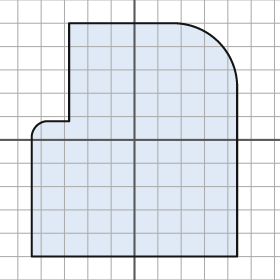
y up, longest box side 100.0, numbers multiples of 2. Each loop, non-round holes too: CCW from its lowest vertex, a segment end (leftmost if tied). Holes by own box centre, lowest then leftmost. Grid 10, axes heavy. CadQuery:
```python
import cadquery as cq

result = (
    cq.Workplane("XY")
    .moveTo(-44.0, -50.0)
    .lineTo(44.0, -50.0)
    .lineTo(44.0, 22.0)
    .threePointArc((36.0, 42.0), (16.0, 50.0))
    .lineTo(-28.0, 50.0)
    .lineTo(-28.0, 8.0)
    .lineTo(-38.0, 8.0)
    .threePointArc((-42.0, 6.0), (-44.0, 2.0))
    .close()
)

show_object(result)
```